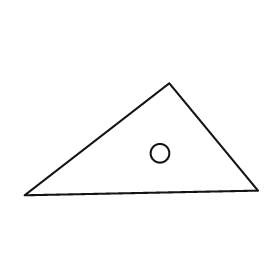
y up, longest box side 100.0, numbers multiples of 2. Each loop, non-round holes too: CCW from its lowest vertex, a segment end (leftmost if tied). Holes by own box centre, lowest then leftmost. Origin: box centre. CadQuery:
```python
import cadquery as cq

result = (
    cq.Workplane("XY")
    .moveTo(-50.0, -24.0)
    .lineTo(50.0, -22.0)
    .lineTo(12.0, 24.0)
    .close()
    .moveTo(8.0, -6.0)
    .circle(4.0)
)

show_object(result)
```